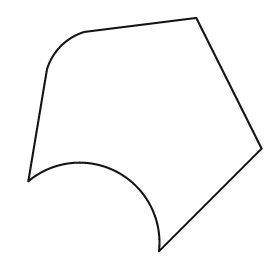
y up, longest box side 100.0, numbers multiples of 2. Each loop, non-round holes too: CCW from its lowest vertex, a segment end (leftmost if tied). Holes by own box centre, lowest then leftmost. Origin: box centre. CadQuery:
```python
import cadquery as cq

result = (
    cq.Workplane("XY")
    .moveTo(6.0, -50.0)
    .lineTo(50.0, -6.0)
    .lineTo(22.0, 50.0)
    .lineTo(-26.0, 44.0)
    .threePointArc((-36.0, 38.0), (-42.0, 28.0))
    .lineTo(-50.0, -20.0)
    .threePointArc((-12.0, -16.0), (6.0, -50.0))
    .close()
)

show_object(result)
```